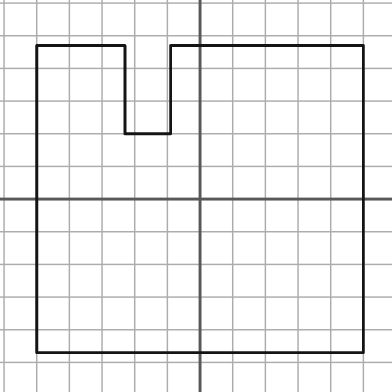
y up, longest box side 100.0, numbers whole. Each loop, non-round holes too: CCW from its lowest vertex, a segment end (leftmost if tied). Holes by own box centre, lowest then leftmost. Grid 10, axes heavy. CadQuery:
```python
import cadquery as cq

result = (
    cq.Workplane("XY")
    .moveTo(-50.0, -47.0)
    .lineTo(50.0, -47.0)
    .lineTo(50.0, 47.0)
    .lineTo(-9.0, 47.0)
    .lineTo(-9.0, 20.0)
    .lineTo(-23.0, 20.0)
    .lineTo(-23.0, 47.0)
    .lineTo(-50.0, 47.0)
    .close()
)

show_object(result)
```